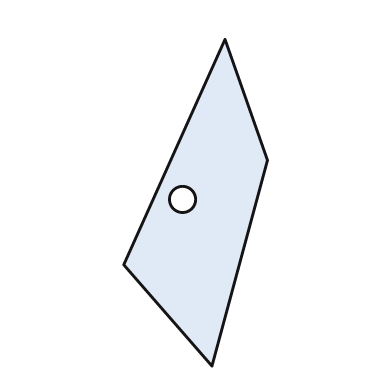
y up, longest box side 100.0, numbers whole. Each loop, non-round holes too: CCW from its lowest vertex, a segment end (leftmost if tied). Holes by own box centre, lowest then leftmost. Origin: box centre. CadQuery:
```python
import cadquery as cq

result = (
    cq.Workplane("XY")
    .moveTo(5.0, -50.0)
    .lineTo(22.0, 13.0)
    .lineTo(9.0, 50.0)
    .lineTo(-22.0, -19.0)
    .close()
    .moveTo(-4.0, 1.0)
    .circle(4.0)
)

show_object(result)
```